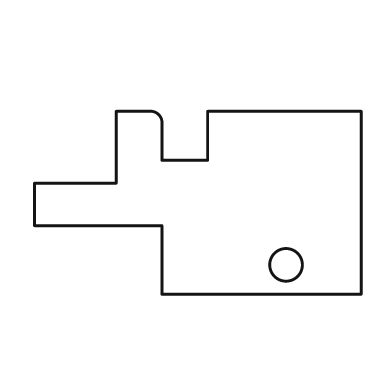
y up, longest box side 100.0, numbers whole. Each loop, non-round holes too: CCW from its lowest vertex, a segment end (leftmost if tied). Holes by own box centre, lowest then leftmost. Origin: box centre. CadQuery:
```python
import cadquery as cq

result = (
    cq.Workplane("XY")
    .moveTo(-11.0, -28.0)
    .lineTo(50.0, -28.0)
    .lineTo(50.0, 28.0)
    .lineTo(3.0, 28.0)
    .lineTo(3.0, 13.0)
    .lineTo(-11.0, 13.0)
    .lineTo(-11.0, 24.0)
    .threePointArc((-12.0, 27.0), (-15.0, 28.0))
    .lineTo(-25.0, 28.0)
    .lineTo(-25.0, 6.0)
    .lineTo(-50.0, 6.0)
    .lineTo(-50.0, -7.0)
    .lineTo(-11.0, -7.0)
    .close()
    .moveTo(27.0, -19.0)
    .circle(5.0)
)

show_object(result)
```